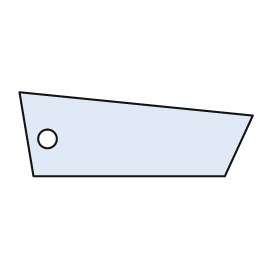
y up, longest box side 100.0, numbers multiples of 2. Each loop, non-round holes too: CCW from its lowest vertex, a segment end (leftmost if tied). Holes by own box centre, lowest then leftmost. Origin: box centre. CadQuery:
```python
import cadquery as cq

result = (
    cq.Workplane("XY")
    .moveTo(-44.0, -18.0)
    .lineTo(38.0, -18.0)
    .lineTo(50.0, 8.0)
    .lineTo(-50.0, 18.0)
    .close()
    .moveTo(-38.0, -2.0)
    .circle(4.0)
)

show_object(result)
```